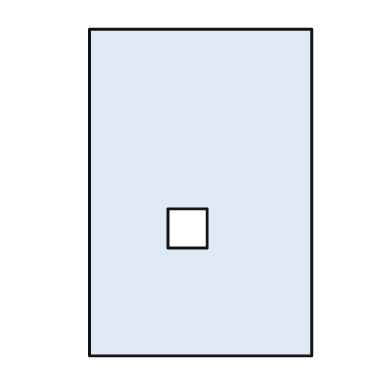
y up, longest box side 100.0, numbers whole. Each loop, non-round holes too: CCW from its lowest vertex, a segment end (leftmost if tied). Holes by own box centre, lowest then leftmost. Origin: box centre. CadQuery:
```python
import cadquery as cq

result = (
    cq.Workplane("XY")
    .moveTo(-34.0, -50.0)
    .lineTo(34.0, -50.0)
    .lineTo(34.0, 50.0)
    .lineTo(-34.0, 50.0)
    .close()
    .moveTo(-10.0, -17.0)
    .lineTo(2.0, -17.0)
    .lineTo(2.0, -5.0)
    .lineTo(-10.0, -5.0)
    .close()
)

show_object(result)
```